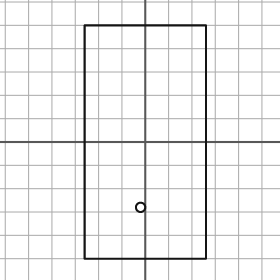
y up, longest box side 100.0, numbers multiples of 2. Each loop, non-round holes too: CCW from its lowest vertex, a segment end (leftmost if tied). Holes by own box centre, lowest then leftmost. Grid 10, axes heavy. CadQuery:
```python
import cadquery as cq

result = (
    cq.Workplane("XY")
    .moveTo(-26.0, -50.0)
    .lineTo(26.0, -50.0)
    .lineTo(26.0, 50.0)
    .lineTo(-26.0, 50.0)
    .close()
    .moveTo(-2.0, -28.0)
    .circle(2.0)
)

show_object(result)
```